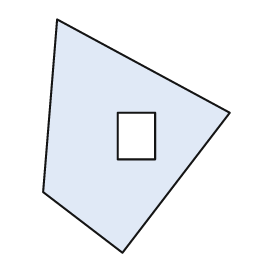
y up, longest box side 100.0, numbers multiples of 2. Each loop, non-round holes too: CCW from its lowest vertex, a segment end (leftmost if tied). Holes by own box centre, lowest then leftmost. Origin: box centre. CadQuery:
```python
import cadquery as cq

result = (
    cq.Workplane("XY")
    .moveTo(-6.0, -50.0)
    .lineTo(40.0, 10.0)
    .lineTo(-34.0, 50.0)
    .lineTo(-40.0, -24.0)
    .close()
    .moveTo(-8.0, -10.0)
    .lineTo(8.0, -10.0)
    .lineTo(8.0, 10.0)
    .lineTo(-8.0, 10.0)
    .close()
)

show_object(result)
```